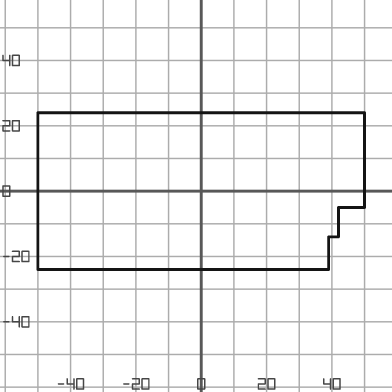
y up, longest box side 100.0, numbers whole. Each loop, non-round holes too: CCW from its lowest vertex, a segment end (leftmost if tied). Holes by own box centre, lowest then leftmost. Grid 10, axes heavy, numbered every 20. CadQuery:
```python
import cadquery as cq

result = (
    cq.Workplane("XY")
    .moveTo(-50.0, -24.0)
    .lineTo(39.0, -24.0)
    .lineTo(39.0, -14.0)
    .lineTo(42.0, -14.0)
    .lineTo(42.0, -5.0)
    .lineTo(50.0, -5.0)
    .lineTo(50.0, 24.0)
    .lineTo(-50.0, 24.0)
    .close()
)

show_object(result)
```